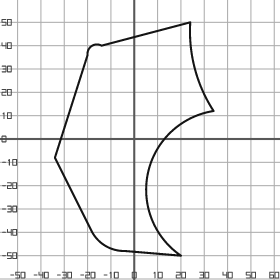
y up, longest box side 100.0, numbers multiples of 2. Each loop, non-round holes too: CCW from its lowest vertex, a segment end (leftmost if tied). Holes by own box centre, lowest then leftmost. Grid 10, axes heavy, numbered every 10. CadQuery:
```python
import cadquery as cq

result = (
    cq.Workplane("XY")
    .moveTo(20.0, -50.0)
    .threePointArc((6.0, -14.0), (34.0, 12.0))
    .threePointArc((26.0, 30.0), (24.0, 50.0))
    .lineTo(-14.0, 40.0)
    .threePointArc((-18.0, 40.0), (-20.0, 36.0))
    .lineTo(-34.0, -8.0)
    .lineTo(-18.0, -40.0)
    .threePointArc((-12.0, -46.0), (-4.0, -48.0))
    .close()
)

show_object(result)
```